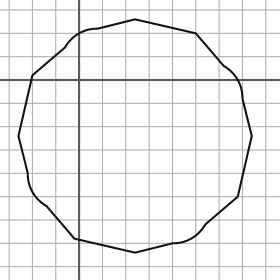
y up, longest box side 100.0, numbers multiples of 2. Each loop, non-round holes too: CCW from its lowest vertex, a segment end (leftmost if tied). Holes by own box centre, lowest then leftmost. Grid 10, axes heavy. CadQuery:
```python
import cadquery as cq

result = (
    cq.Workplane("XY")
    .moveTo(24.0, -74.0)
    .lineTo(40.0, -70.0)
    .threePointArc((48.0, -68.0), (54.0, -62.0))
    .lineTo(68.0, -50.0)
    .lineTo(74.0, -24.0)
    .lineTo(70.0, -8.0)
    .threePointArc((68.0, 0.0), (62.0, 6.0))
    .lineTo(50.0, 20.0)
    .lineTo(24.0, 26.0)
    .lineTo(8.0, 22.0)
    .threePointArc((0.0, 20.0), (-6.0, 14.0))
    .lineTo(-20.0, 2.0)
    .lineTo(-26.0, -24.0)
    .lineTo(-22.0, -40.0)
    .threePointArc((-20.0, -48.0), (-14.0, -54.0))
    .lineTo(-2.0, -68.0)
    .close()
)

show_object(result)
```